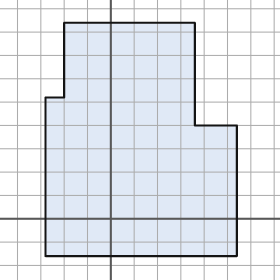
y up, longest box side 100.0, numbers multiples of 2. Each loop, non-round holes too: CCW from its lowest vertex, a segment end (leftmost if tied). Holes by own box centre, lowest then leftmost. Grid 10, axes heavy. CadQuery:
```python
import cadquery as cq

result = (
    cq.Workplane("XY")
    .moveTo(-28.0, -16.0)
    .lineTo(54.0, -16.0)
    .lineTo(54.0, 40.0)
    .lineTo(36.0, 40.0)
    .lineTo(36.0, 84.0)
    .lineTo(-20.0, 84.0)
    .lineTo(-20.0, 52.0)
    .lineTo(-28.0, 52.0)
    .close()
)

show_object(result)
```